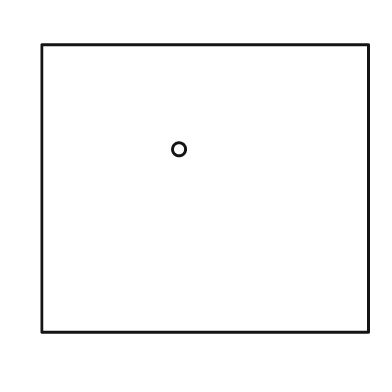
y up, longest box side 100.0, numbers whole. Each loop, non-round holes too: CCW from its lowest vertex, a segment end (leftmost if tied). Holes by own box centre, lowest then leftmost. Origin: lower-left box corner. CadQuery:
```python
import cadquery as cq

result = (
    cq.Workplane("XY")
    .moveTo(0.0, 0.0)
    .lineTo(100.0, 0.0)
    .lineTo(100.0, 88.0)
    .lineTo(0.0, 88.0)
    .close()
    .moveTo(42.0, 56.0)
    .circle(2.0)
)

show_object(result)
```